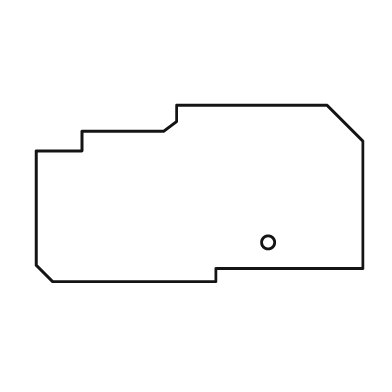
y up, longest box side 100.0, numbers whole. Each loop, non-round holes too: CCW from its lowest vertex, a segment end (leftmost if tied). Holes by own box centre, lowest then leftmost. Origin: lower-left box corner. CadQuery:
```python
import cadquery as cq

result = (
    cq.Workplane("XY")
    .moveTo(5.0, 0.0)
    .lineTo(55.0, 0.0)
    .lineTo(55.0, 4.0)
    .lineTo(100.0, 4.0)
    .lineTo(100.0, 43.0)
    .lineTo(89.0, 54.0)
    .lineTo(43.0, 54.0)
    .lineTo(43.0, 49.0)
    .lineTo(39.0, 46.0)
    .lineTo(14.0, 46.0)
    .lineTo(14.0, 40.0)
    .lineTo(0.0, 40.0)
    .lineTo(0.0, 5.0)
    .close()
    .moveTo(71.0, 12.0)
    .circle(2.0)
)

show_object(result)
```